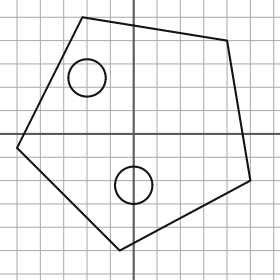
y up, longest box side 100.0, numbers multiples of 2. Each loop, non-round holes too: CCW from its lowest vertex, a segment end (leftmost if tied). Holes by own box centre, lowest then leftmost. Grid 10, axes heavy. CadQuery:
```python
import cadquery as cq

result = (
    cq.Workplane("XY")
    .moveTo(-6.0, -50.0)
    .lineTo(50.0, -20.0)
    .lineTo(40.0, 40.0)
    .lineTo(-22.0, 50.0)
    .lineTo(-50.0, -6.0)
    .close()
    .moveTo(0.0, -22.0)
    .circle(8.0)
    .moveTo(-20.0, 24.0)
    .circle(8.0)
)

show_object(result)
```